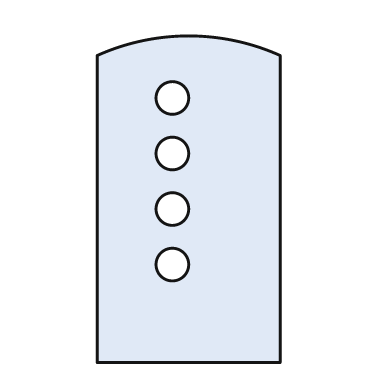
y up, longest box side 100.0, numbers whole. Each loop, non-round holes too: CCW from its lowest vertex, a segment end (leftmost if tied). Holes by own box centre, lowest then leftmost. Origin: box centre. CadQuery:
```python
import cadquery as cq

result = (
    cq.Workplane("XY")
    .moveTo(-28.0, -50.0)
    .lineTo(28.0, -50.0)
    .lineTo(28.0, 44.0)
    .threePointArc((0.0, 50.0), (-28.0, 44.0))
    .close()
    .moveTo(-5.0, -20.0)
    .circle(5.0)
    .moveTo(-5.0, -3.0)
    .circle(5.0)
    .moveTo(-5.0, 14.0)
    .circle(5.0)
    .moveTo(-5.0, 31.0)
    .circle(5.0)
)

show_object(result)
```